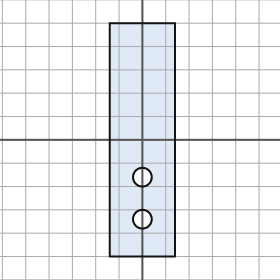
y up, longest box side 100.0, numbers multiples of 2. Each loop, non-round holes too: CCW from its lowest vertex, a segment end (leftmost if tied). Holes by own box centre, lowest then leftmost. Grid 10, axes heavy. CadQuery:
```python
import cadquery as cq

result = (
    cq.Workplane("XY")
    .moveTo(-14.0, -50.0)
    .lineTo(14.0, -50.0)
    .lineTo(14.0, 50.0)
    .lineTo(-14.0, 50.0)
    .close()
    .moveTo(0.0, -34.0)
    .circle(4.0)
    .moveTo(0.0, -16.0)
    .circle(4.0)
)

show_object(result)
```